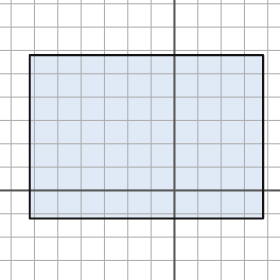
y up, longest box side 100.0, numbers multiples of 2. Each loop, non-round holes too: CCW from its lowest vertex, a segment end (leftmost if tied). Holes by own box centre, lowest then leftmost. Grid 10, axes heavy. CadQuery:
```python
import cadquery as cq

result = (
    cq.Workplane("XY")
    .moveTo(-62.0, -12.0)
    .lineTo(38.0, -12.0)
    .lineTo(38.0, 58.0)
    .lineTo(-62.0, 58.0)
    .close()
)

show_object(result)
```